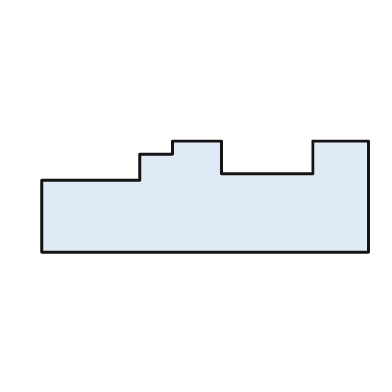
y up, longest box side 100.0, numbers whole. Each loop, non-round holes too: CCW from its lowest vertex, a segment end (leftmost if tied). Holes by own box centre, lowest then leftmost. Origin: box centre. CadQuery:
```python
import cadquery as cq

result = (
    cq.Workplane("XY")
    .moveTo(-50.0, -17.0)
    .lineTo(50.0, -17.0)
    .lineTo(50.0, 17.0)
    .lineTo(33.0, 17.0)
    .lineTo(33.0, 7.0)
    .lineTo(5.0, 7.0)
    .lineTo(5.0, 17.0)
    .lineTo(-10.0, 17.0)
    .lineTo(-10.0, 13.0)
    .lineTo(-20.0, 13.0)
    .lineTo(-20.0, 5.0)
    .lineTo(-50.0, 5.0)
    .close()
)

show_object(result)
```